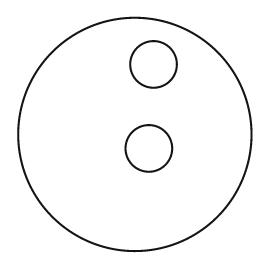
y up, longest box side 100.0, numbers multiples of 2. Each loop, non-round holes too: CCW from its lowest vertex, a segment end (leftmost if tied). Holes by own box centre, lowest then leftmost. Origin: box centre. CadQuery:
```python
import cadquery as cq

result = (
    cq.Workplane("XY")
    .moveTo(0.0, 0.0)
    .circle(50.0)
    .moveTo(6.0, -6.0)
    .circle(10.0)
    .moveTo(8.0, 30.0)
    .circle(10.0)
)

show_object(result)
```